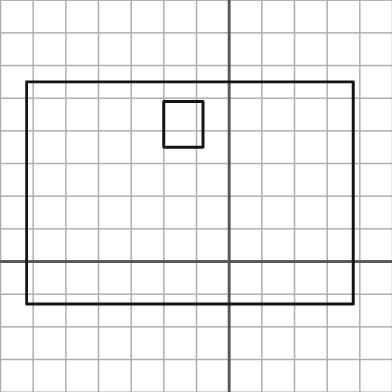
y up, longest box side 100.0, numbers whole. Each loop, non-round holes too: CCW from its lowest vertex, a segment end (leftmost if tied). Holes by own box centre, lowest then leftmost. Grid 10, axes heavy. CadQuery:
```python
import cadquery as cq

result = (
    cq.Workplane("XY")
    .moveTo(-62.0, -13.0)
    .lineTo(38.0, -13.0)
    .lineTo(38.0, 55.0)
    .lineTo(-62.0, 55.0)
    .close()
    .moveTo(-20.0, 35.0)
    .lineTo(-8.0, 35.0)
    .lineTo(-8.0, 49.0)
    .lineTo(-20.0, 49.0)
    .close()
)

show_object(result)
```